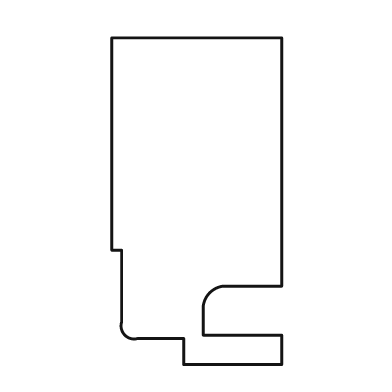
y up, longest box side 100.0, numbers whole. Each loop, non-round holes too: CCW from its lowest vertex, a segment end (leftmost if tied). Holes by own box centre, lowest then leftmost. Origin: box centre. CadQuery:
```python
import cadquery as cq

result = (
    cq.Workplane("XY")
    .moveTo(-4.0, -50.0)
    .lineTo(26.0, -50.0)
    .lineTo(26.0, -41.0)
    .lineTo(2.0, -41.0)
    .lineTo(2.0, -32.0)
    .threePointArc((4.0, -28.0), (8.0, -26.0))
    .lineTo(26.0, -26.0)
    .lineTo(26.0, 50.0)
    .lineTo(-26.0, 50.0)
    .lineTo(-26.0, -15.0)
    .lineTo(-23.0, -15.0)
    .lineTo(-23.0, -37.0)
    .threePointArc((-22.0, -41.0), (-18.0, -42.0))
    .lineTo(-4.0, -42.0)
    .close()
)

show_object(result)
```